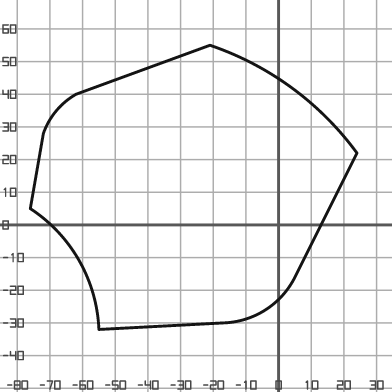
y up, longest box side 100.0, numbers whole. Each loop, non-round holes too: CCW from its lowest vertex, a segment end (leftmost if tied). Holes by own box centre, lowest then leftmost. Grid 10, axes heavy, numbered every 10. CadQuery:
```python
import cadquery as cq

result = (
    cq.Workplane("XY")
    .moveTo(-55.0, -32.0)
    .lineTo(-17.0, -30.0)
    .threePointArc((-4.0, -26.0), (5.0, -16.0))
    .lineTo(24.0, 22.0)
    .threePointArc((4.0, 42.0), (-21.0, 55.0))
    .lineTo(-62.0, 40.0)
    .threePointArc((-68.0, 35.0), (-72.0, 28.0))
    .lineTo(-76.0, 5.0)
    .threePointArc((-61.0, -11.0), (-55.0, -32.0))
    .close()
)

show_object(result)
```